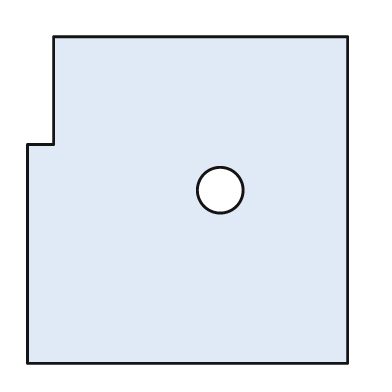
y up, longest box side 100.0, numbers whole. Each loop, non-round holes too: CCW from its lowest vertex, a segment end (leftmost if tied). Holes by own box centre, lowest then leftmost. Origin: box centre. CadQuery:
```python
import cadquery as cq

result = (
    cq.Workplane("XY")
    .moveTo(-49.0, -50.0)
    .lineTo(49.0, -50.0)
    .lineTo(49.0, 50.0)
    .lineTo(-41.0, 50.0)
    .lineTo(-41.0, 17.0)
    .lineTo(-49.0, 17.0)
    .close()
    .moveTo(10.0, 3.0)
    .circle(7.0)
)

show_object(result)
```